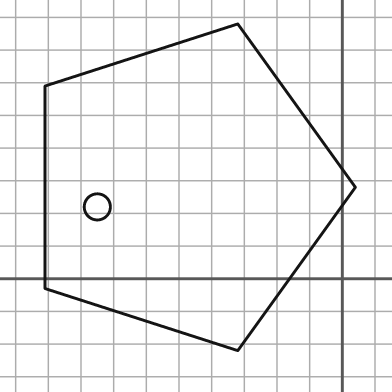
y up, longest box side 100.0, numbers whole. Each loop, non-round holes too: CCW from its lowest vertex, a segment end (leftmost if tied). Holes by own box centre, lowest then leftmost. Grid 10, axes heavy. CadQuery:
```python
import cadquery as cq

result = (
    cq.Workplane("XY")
    .moveTo(-32.0, -22.0)
    .lineTo(4.0, 28.0)
    .lineTo(-32.0, 78.0)
    .lineTo(-91.0, 59.0)
    .lineTo(-91.0, -3.0)
    .close()
    .moveTo(-75.0, 22.0)
    .circle(4.0)
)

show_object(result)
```